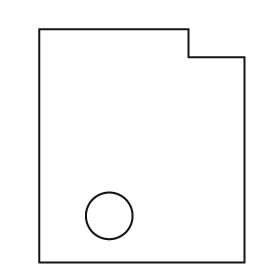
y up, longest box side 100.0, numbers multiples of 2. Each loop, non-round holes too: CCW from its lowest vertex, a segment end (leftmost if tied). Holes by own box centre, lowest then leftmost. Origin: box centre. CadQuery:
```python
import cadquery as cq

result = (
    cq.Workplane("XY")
    .moveTo(-44.0, -50.0)
    .lineTo(44.0, -50.0)
    .lineTo(44.0, 38.0)
    .lineTo(20.0, 38.0)
    .lineTo(20.0, 50.0)
    .lineTo(-44.0, 50.0)
    .close()
    .moveTo(-14.0, -30.0)
    .circle(10.0)
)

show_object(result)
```